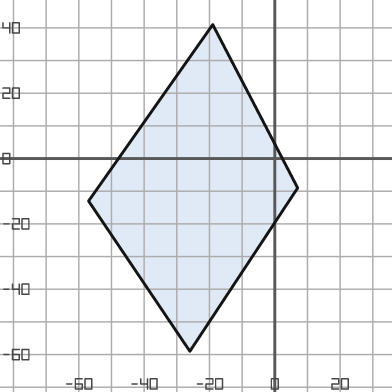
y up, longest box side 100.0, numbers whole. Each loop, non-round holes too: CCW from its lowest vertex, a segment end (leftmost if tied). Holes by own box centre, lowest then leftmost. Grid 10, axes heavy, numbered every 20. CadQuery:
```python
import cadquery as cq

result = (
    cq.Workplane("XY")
    .moveTo(-26.0, -59.0)
    .lineTo(7.0, -9.0)
    .lineTo(-19.0, 41.0)
    .lineTo(-57.0, -13.0)
    .close()
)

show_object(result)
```